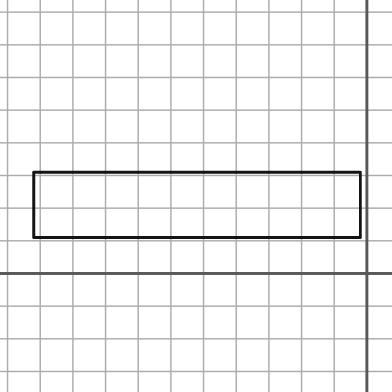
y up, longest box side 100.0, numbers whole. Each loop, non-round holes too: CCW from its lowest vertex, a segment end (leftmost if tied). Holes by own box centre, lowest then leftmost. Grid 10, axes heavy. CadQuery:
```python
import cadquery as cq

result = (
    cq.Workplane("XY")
    .moveTo(-102.0, 11.0)
    .lineTo(-2.0, 11.0)
    .lineTo(-2.0, 31.0)
    .lineTo(-102.0, 31.0)
    .close()
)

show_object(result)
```